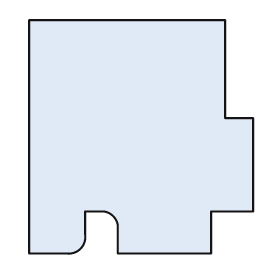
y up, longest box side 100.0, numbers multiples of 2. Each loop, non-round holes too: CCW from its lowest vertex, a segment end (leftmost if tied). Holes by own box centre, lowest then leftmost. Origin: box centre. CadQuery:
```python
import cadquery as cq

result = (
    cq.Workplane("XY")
    .moveTo(-48.0, -50.0)
    .lineTo(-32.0, -50.0)
    .threePointArc((-26.0, -48.0), (-24.0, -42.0))
    .lineTo(-24.0, -32.0)
    .lineTo(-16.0, -32.0)
    .threePointArc((-12.0, -34.0), (-10.0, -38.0))
    .lineTo(-10.0, -50.0)
    .lineTo(30.0, -50.0)
    .lineTo(30.0, -32.0)
    .lineTo(48.0, -32.0)
    .lineTo(48.0, 8.0)
    .lineTo(36.0, 8.0)
    .lineTo(36.0, 50.0)
    .lineTo(-48.0, 50.0)
    .close()
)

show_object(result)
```